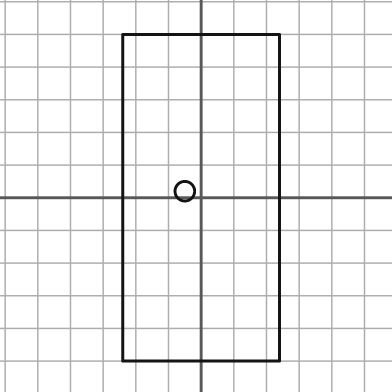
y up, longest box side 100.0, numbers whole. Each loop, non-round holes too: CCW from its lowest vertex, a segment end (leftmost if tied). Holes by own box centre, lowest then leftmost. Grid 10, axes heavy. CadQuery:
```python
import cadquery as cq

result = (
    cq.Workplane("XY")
    .moveTo(-24.0, -50.0)
    .lineTo(24.0, -50.0)
    .lineTo(24.0, 50.0)
    .lineTo(-24.0, 50.0)
    .close()
    .moveTo(-5.0, 2.0)
    .circle(3.0)
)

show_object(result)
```